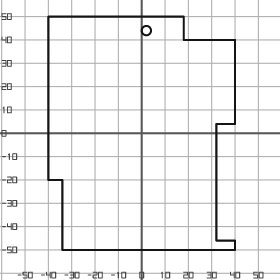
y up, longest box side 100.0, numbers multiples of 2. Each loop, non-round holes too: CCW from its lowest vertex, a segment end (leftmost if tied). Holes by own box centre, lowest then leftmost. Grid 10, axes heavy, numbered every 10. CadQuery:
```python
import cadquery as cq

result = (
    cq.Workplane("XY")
    .moveTo(-34.0, -50.0)
    .lineTo(40.0, -50.0)
    .lineTo(40.0, -46.0)
    .lineTo(32.0, -46.0)
    .lineTo(32.0, 4.0)
    .lineTo(40.0, 4.0)
    .lineTo(40.0, 40.0)
    .lineTo(18.0, 40.0)
    .lineTo(18.0, 50.0)
    .lineTo(-40.0, 50.0)
    .lineTo(-40.0, -20.0)
    .lineTo(-34.0, -20.0)
    .close()
    .moveTo(2.0, 44.0)
    .circle(2.0)
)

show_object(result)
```